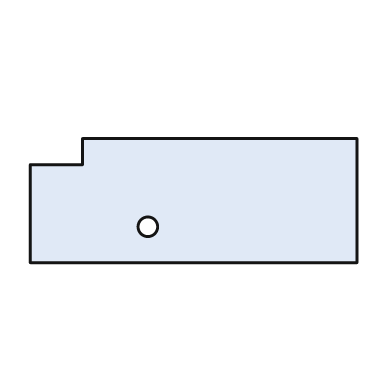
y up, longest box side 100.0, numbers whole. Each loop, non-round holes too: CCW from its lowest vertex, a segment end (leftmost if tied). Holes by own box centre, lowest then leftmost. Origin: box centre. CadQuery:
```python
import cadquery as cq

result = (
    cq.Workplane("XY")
    .moveTo(-50.0, -19.0)
    .lineTo(50.0, -19.0)
    .lineTo(50.0, 19.0)
    .lineTo(-34.0, 19.0)
    .lineTo(-34.0, 11.0)
    .lineTo(-50.0, 11.0)
    .close()
    .moveTo(-14.0, -8.0)
    .circle(3.0)
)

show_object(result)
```